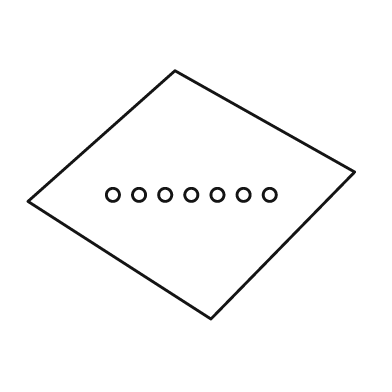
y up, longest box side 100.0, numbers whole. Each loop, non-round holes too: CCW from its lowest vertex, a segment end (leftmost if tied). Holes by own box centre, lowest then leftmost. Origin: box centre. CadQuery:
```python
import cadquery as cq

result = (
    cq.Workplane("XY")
    .moveTo(6.0, -38.0)
    .lineTo(50.0, 7.0)
    .lineTo(-5.0, 38.0)
    .lineTo(-50.0, -2.0)
    .close()
    .moveTo(-24.0, 0.0)
    .circle(2.0)
    .moveTo(-16.0, 0.0)
    .circle(2.0)
    .moveTo(-8.0, 0.0)
    .circle(2.0)
    .moveTo(0.0, 0.0)
    .circle(2.0)
    .moveTo(8.0, 0.0)
    .circle(2.0)
    .moveTo(16.0, 0.0)
    .circle(2.0)
    .moveTo(24.0, 0.0)
    .circle(2.0)
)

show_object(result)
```